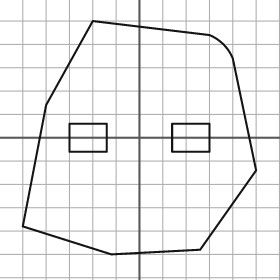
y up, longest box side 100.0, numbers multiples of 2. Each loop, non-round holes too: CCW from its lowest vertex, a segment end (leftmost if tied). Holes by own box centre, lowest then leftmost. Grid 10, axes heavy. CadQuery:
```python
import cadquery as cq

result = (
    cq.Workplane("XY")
    .moveTo(-12.0, -50.0)
    .lineTo(26.0, -48.0)
    .lineTo(50.0, -14.0)
    .lineTo(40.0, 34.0)
    .threePointArc((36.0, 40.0), (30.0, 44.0))
    .lineTo(-20.0, 50.0)
    .lineTo(-40.0, 14.0)
    .lineTo(-50.0, -38.0)
    .close()
    .moveTo(-30.0, -6.0)
    .lineTo(-14.0, -6.0)
    .lineTo(-14.0, 6.0)
    .lineTo(-30.0, 6.0)
    .close()
    .moveTo(14.0, -6.0)
    .lineTo(30.0, -6.0)
    .lineTo(30.0, 6.0)
    .lineTo(14.0, 6.0)
    .close()
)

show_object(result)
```